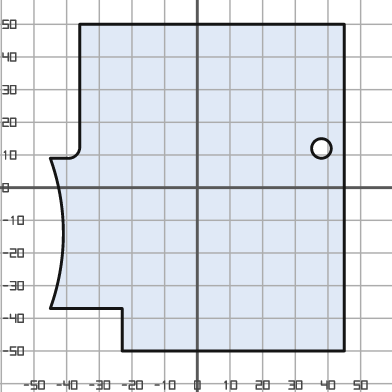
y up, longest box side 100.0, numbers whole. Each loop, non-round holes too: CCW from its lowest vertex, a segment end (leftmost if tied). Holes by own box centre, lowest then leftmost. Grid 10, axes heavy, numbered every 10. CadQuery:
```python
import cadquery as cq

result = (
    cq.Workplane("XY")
    .moveTo(-23.0, -50.0)
    .lineTo(45.0, -50.0)
    .lineTo(45.0, 50.0)
    .lineTo(-36.0, 50.0)
    .lineTo(-36.0, 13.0)
    .threePointArc((-37.0, 10.0), (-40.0, 9.0))
    .lineTo(-45.0, 9.0)
    .threePointArc((-41.0, -14.0), (-45.0, -37.0))
    .lineTo(-23.0, -37.0)
    .close()
    .moveTo(38.0, 12.0)
    .circle(3.0)
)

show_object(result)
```